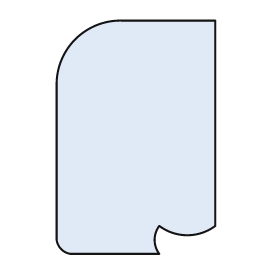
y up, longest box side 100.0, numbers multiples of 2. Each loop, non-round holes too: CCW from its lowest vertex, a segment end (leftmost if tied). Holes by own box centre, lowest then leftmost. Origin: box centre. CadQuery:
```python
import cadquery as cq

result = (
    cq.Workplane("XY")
    .moveTo(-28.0, -50.0)
    .lineTo(10.0, -50.0)
    .threePointArc((8.0, -44.0), (10.0, -38.0))
    .threePointArc((22.0, -42.0), (34.0, -38.0))
    .lineTo(34.0, 50.0)
    .lineTo(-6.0, 50.0)
    .threePointArc((-26.0, 42.0), (-34.0, 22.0))
    .lineTo(-34.0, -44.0)
    .threePointArc((-32.0, -48.0), (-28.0, -50.0))
    .close()
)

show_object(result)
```